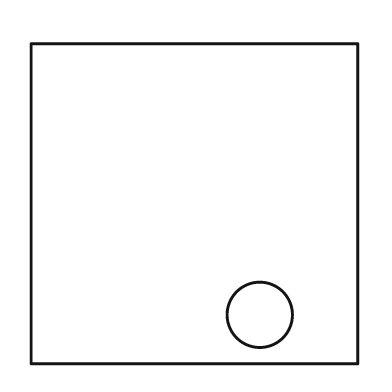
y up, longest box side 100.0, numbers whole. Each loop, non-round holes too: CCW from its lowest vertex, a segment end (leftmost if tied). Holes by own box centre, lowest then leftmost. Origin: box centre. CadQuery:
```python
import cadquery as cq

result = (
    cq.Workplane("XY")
    .moveTo(-50.0, -49.0)
    .lineTo(50.0, -49.0)
    .lineTo(50.0, 49.0)
    .lineTo(-50.0, 49.0)
    .close()
    .moveTo(20.0, -34.0)
    .circle(10.0)
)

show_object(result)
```